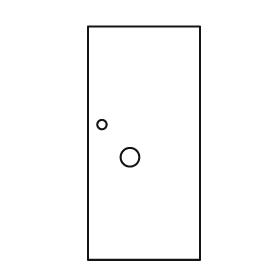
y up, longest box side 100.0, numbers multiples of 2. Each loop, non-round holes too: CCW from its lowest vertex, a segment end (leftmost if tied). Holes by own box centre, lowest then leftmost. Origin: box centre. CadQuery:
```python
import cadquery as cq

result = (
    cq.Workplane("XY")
    .moveTo(-24.0, -50.0)
    .lineTo(24.0, -50.0)
    .lineTo(24.0, 50.0)
    .lineTo(-24.0, 50.0)
    .close()
    .moveTo(-6.0, -6.0)
    .circle(4.0)
    .moveTo(-18.0, 8.0)
    .circle(2.0)
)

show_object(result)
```